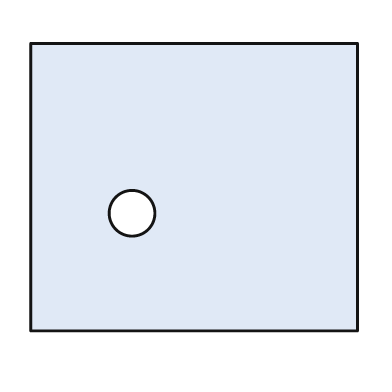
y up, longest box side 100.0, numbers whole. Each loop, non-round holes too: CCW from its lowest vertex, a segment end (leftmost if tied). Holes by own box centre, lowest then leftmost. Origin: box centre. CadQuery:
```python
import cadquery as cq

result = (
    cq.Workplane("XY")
    .moveTo(-50.0, -44.0)
    .lineTo(50.0, -44.0)
    .lineTo(50.0, 44.0)
    .lineTo(-50.0, 44.0)
    .close()
    .moveTo(-19.0, -8.0)
    .circle(7.0)
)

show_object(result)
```